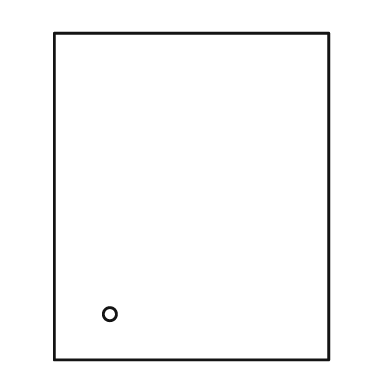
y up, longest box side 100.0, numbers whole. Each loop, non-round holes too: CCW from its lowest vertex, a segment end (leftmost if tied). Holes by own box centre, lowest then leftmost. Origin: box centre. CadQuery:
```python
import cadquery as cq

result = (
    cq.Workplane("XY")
    .moveTo(-42.0, -50.0)
    .lineTo(42.0, -50.0)
    .lineTo(42.0, 50.0)
    .lineTo(-42.0, 50.0)
    .close()
    .moveTo(-25.0, -36.0)
    .circle(2.0)
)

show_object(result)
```